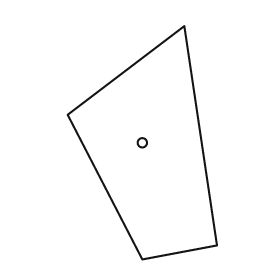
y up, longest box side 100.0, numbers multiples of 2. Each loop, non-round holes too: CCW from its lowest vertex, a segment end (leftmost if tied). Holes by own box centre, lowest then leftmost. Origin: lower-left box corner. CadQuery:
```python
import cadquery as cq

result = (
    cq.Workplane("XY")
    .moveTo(32.0, 0.0)
    .lineTo(64.0, 6.0)
    .lineTo(50.0, 100.0)
    .lineTo(0.0, 62.0)
    .close()
    .moveTo(32.0, 50.0)
    .circle(2.0)
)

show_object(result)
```